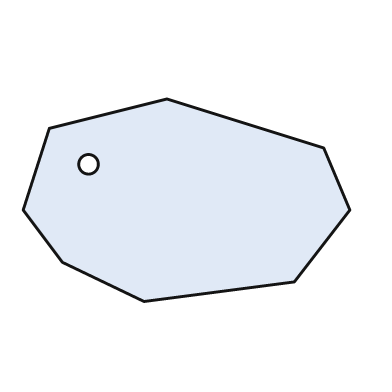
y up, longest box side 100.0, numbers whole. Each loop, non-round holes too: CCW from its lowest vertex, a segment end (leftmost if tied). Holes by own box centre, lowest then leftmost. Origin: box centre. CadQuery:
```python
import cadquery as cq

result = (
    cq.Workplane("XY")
    .moveTo(-13.0, -31.0)
    .lineTo(33.0, -25.0)
    .lineTo(50.0, -3.0)
    .lineTo(42.0, 16.0)
    .lineTo(-6.0, 31.0)
    .lineTo(-42.0, 22.0)
    .lineTo(-50.0, -3.0)
    .lineTo(-38.0, -19.0)
    .close()
    .moveTo(-30.0, 11.0)
    .circle(3.0)
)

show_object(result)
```